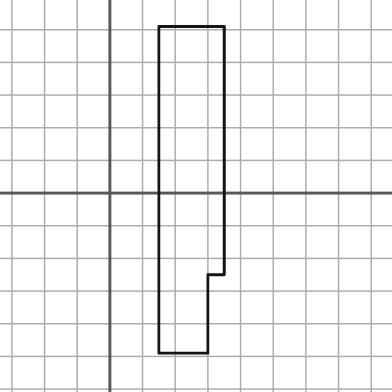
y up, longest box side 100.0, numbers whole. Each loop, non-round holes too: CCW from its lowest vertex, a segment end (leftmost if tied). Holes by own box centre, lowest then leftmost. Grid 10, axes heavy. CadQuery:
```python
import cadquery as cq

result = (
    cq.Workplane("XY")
    .moveTo(15.0, -49.0)
    .lineTo(30.0, -49.0)
    .lineTo(30.0, -25.0)
    .lineTo(35.0, -25.0)
    .lineTo(35.0, 51.0)
    .lineTo(15.0, 51.0)
    .close()
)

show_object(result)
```